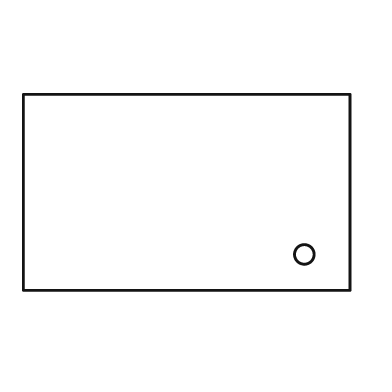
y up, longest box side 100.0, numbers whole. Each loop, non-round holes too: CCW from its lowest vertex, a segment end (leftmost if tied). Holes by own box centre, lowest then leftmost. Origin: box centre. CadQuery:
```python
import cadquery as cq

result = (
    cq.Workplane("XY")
    .moveTo(-50.0, -30.0)
    .lineTo(50.0, -30.0)
    .lineTo(50.0, 30.0)
    .lineTo(-50.0, 30.0)
    .close()
    .moveTo(36.0, -19.0)
    .circle(3.0)
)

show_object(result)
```